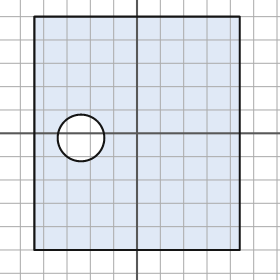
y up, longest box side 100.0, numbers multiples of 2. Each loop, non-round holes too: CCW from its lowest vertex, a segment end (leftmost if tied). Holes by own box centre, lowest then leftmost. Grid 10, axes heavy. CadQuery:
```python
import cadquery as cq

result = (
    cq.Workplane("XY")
    .moveTo(-44.0, -50.0)
    .lineTo(44.0, -50.0)
    .lineTo(44.0, 50.0)
    .lineTo(-44.0, 50.0)
    .close()
    .moveTo(-24.0, -2.0)
    .circle(10.0)
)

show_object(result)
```